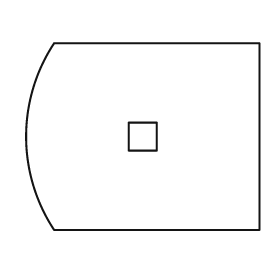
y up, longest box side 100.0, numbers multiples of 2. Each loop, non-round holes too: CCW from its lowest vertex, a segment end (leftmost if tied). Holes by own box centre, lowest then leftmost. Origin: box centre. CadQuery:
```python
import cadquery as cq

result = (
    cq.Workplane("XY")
    .moveTo(-38.0, -40.0)
    .lineTo(50.0, -40.0)
    .lineTo(50.0, 40.0)
    .lineTo(-38.0, 40.0)
    .threePointArc((-50.0, 0.0), (-38.0, -40.0))
    .close()
    .moveTo(-6.0, -6.0)
    .lineTo(6.0, -6.0)
    .lineTo(6.0, 6.0)
    .lineTo(-6.0, 6.0)
    .close()
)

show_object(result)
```